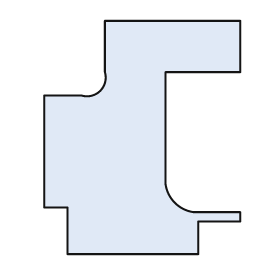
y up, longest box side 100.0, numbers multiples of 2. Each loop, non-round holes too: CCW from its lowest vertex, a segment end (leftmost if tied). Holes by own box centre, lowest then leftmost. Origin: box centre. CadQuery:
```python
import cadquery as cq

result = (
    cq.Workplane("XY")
    .moveTo(-32.0, -50.0)
    .lineTo(24.0, -50.0)
    .lineTo(24.0, -36.0)
    .lineTo(42.0, -36.0)
    .lineTo(42.0, -32.0)
    .lineTo(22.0, -32.0)
    .threePointArc((14.0, -28.0), (10.0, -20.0))
    .lineTo(10.0, 28.0)
    .lineTo(42.0, 28.0)
    .lineTo(42.0, 50.0)
    .lineTo(-16.0, 50.0)
    .lineTo(-16.0, 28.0)
    .threePointArc((-18.0, 20.0), (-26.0, 18.0))
    .lineTo(-42.0, 18.0)
    .lineTo(-42.0, -30.0)
    .lineTo(-32.0, -30.0)
    .close()
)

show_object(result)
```